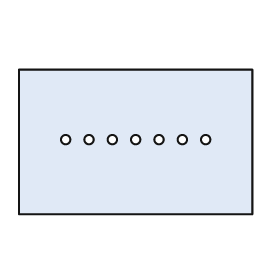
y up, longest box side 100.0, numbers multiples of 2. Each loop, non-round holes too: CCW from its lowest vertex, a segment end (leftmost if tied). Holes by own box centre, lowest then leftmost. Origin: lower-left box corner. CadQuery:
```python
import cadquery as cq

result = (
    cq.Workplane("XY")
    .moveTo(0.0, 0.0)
    .lineTo(100.0, 0.0)
    .lineTo(100.0, 62.0)
    .lineTo(0.0, 62.0)
    .close()
    .moveTo(20.0, 32.0)
    .circle(2.0)
    .moveTo(30.0, 32.0)
    .circle(2.0)
    .moveTo(40.0, 32.0)
    .circle(2.0)
    .moveTo(50.0, 32.0)
    .circle(2.0)
    .moveTo(60.0, 32.0)
    .circle(2.0)
    .moveTo(70.0, 32.0)
    .circle(2.0)
    .moveTo(80.0, 32.0)
    .circle(2.0)
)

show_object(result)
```